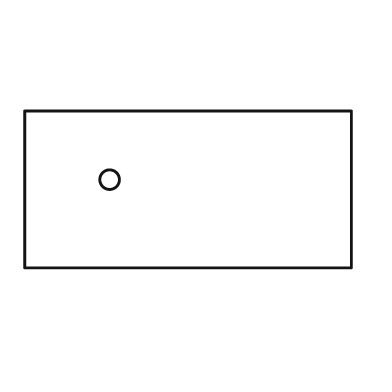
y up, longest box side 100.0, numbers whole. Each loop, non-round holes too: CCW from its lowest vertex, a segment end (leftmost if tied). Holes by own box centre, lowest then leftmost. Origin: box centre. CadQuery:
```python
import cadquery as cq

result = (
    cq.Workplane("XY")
    .moveTo(-50.0, -24.0)
    .lineTo(50.0, -24.0)
    .lineTo(50.0, 24.0)
    .lineTo(-50.0, 24.0)
    .close()
    .moveTo(-24.0, 3.0)
    .circle(3.0)
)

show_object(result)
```